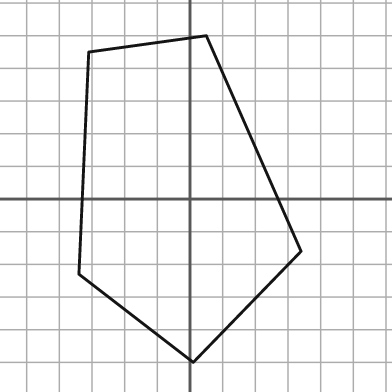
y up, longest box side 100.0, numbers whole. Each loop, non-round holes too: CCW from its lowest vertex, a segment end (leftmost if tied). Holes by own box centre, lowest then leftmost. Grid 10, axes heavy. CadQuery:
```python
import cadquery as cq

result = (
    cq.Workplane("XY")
    .moveTo(1.0, -50.0)
    .lineTo(34.0, -16.0)
    .lineTo(5.0, 50.0)
    .lineTo(-31.0, 45.0)
    .lineTo(-34.0, -23.0)
    .close()
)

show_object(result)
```